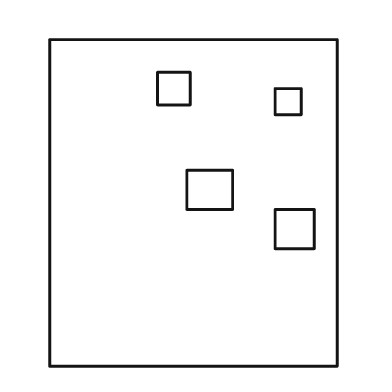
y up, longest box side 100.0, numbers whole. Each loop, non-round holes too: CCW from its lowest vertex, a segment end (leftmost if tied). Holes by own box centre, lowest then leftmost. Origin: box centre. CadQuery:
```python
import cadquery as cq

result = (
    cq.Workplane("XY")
    .moveTo(-44.0, -50.0)
    .lineTo(44.0, -50.0)
    .lineTo(44.0, 50.0)
    .lineTo(-44.0, 50.0)
    .close()
    .moveTo(25.0, -14.0)
    .lineTo(37.0, -14.0)
    .lineTo(37.0, -2.0)
    .lineTo(25.0, -2.0)
    .close()
    .moveTo(-2.0, -2.0)
    .lineTo(12.0, -2.0)
    .lineTo(12.0, 10.0)
    .lineTo(-2.0, 10.0)
    .close()
    .moveTo(25.0, 27.0)
    .lineTo(33.0, 27.0)
    .lineTo(33.0, 35.0)
    .lineTo(25.0, 35.0)
    .close()
    .moveTo(-11.0, 30.0)
    .lineTo(-1.0, 30.0)
    .lineTo(-1.0, 40.0)
    .lineTo(-11.0, 40.0)
    .close()
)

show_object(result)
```